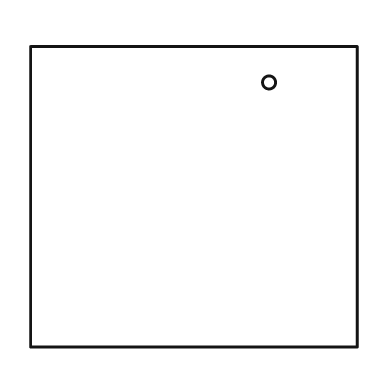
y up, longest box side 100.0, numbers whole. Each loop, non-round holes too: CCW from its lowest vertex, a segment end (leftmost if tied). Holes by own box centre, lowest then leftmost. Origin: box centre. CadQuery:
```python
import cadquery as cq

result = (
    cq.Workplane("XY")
    .moveTo(-50.0, -46.0)
    .lineTo(50.0, -46.0)
    .lineTo(50.0, 46.0)
    .lineTo(-50.0, 46.0)
    .close()
    .moveTo(23.0, 35.0)
    .circle(2.0)
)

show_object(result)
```